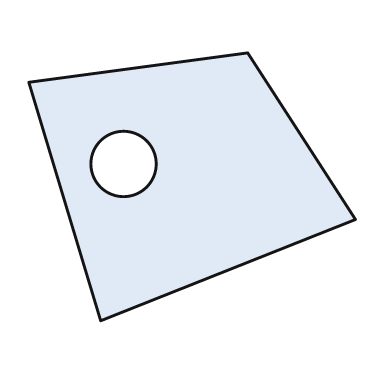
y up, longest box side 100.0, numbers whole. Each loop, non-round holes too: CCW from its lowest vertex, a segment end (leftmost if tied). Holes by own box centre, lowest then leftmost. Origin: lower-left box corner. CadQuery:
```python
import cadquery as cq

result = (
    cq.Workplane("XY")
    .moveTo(22.0, 0.0)
    .lineTo(100.0, 31.0)
    .lineTo(67.0, 82.0)
    .lineTo(0.0, 73.0)
    .close()
    .moveTo(29.0, 48.0)
    .circle(10.0)
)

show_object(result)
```